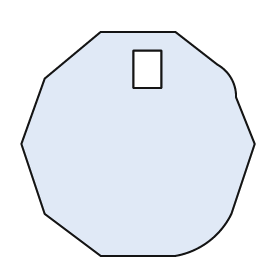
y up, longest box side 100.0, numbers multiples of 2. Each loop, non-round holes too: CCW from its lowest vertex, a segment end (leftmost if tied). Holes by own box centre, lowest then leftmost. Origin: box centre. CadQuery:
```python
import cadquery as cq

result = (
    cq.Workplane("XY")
    .moveTo(-16.0, -48.0)
    .lineTo(16.0, -48.0)
    .threePointArc((30.0, -42.0), (40.0, -30.0))
    .lineTo(50.0, 0.0)
    .lineTo(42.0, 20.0)
    .threePointArc((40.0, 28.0), (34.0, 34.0))
    .lineTo(16.0, 48.0)
    .lineTo(-16.0, 48.0)
    .lineTo(-40.0, 28.0)
    .lineTo(-50.0, 0.0)
    .lineTo(-40.0, -30.0)
    .close()
    .moveTo(-2.0, 24.0)
    .lineTo(10.0, 24.0)
    .lineTo(10.0, 40.0)
    .lineTo(-2.0, 40.0)
    .close()
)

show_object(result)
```